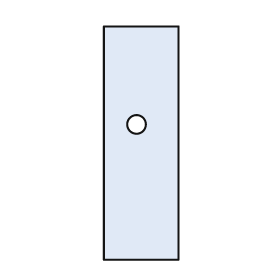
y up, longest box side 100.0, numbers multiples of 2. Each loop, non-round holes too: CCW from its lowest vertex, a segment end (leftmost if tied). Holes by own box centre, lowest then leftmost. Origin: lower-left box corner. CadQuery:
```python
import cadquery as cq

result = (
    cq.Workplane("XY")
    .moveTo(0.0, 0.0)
    .lineTo(32.0, 0.0)
    .lineTo(32.0, 100.0)
    .lineTo(0.0, 100.0)
    .close()
    .moveTo(14.0, 58.0)
    .circle(4.0)
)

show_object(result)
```